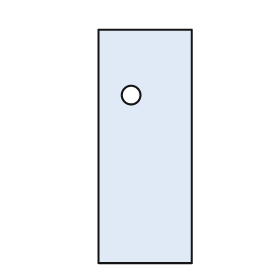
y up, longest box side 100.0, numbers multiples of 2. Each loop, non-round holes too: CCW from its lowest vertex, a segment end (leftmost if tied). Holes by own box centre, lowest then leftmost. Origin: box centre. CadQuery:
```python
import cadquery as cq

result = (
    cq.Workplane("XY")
    .moveTo(-20.0, -50.0)
    .lineTo(20.0, -50.0)
    .lineTo(20.0, 50.0)
    .lineTo(-20.0, 50.0)
    .close()
    .moveTo(-6.0, 22.0)
    .circle(4.0)
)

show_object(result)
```